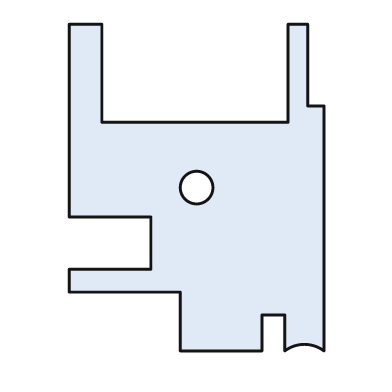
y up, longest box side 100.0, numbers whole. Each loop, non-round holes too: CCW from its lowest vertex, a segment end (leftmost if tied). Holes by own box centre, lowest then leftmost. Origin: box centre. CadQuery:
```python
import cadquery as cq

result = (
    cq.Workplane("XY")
    .moveTo(-5.0, -50.0)
    .lineTo(20.0, -50.0)
    .lineTo(20.0, -39.0)
    .lineTo(27.0, -39.0)
    .lineTo(27.0, -50.0)
    .threePointArc((33.0, -48.0), (39.0, -50.0))
    .lineTo(39.0, 25.0)
    .lineTo(34.0, 25.0)
    .lineTo(34.0, 50.0)
    .lineTo(28.0, 50.0)
    .lineTo(28.0, 20.0)
    .lineTo(-29.0, 20.0)
    .lineTo(-29.0, 50.0)
    .lineTo(-39.0, 50.0)
    .lineTo(-39.0, -9.0)
    .lineTo(-14.0, -9.0)
    .lineTo(-14.0, -25.0)
    .lineTo(-39.0, -25.0)
    .lineTo(-39.0, -32.0)
    .lineTo(-5.0, -32.0)
    .close()
    .moveTo(0.0, 0.0)
    .circle(5.0)
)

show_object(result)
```